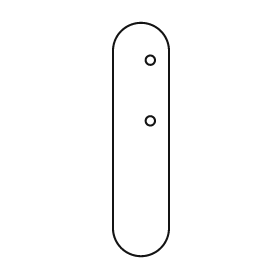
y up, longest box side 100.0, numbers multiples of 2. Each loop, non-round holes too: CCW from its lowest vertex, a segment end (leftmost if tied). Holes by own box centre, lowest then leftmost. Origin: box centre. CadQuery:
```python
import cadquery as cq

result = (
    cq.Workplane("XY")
    .moveTo(-12.0, -38.0)
    .threePointArc((0.0, -50.0), (12.0, -38.0))
    .lineTo(12.0, 38.0)
    .threePointArc((0.0, 50.0), (-12.0, 38.0))
    .close()
    .moveTo(4.0, 8.0)
    .circle(2.0)
    .moveTo(4.0, 34.0)
    .circle(2.0)
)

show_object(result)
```